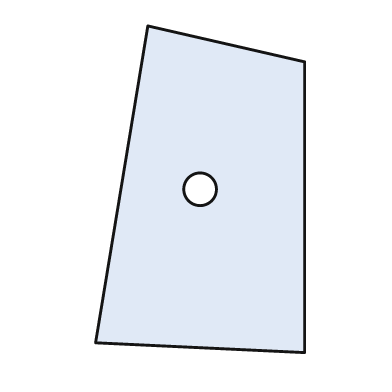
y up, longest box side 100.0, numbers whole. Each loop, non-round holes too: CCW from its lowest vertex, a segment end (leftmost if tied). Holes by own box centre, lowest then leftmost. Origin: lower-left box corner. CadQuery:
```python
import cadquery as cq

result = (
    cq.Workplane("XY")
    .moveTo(64.0, 0.0)
    .lineTo(64.0, 89.0)
    .lineTo(16.0, 100.0)
    .lineTo(0.0, 3.0)
    .close()
    .moveTo(32.0, 50.0)
    .circle(5.0)
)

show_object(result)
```